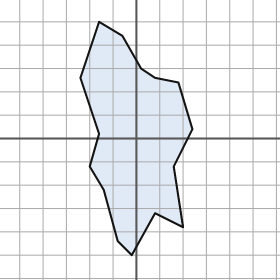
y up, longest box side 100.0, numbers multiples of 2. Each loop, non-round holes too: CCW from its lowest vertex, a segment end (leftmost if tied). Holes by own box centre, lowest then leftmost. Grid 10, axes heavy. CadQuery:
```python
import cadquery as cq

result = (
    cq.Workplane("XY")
    .moveTo(-2.0, -50.0)
    .lineTo(8.0, -32.0)
    .lineTo(20.0, -38.0)
    .lineTo(16.0, -12.0)
    .lineTo(24.0, 4.0)
    .lineTo(18.0, 24.0)
    .lineTo(8.0, 26.0)
    .lineTo(2.0, 30.0)
    .lineTo(-6.0, 44.0)
    .lineTo(-16.0, 50.0)
    .lineTo(-24.0, 26.0)
    .lineTo(-16.0, 2.0)
    .lineTo(-20.0, -12.0)
    .lineTo(-14.0, -22.0)
    .lineTo(-8.0, -44.0)
    .close()
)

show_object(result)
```